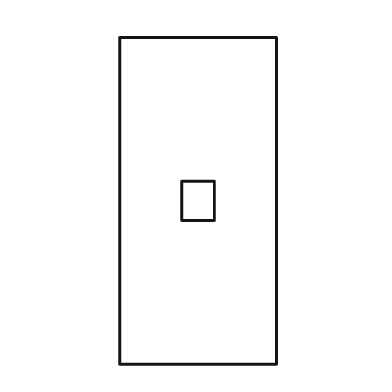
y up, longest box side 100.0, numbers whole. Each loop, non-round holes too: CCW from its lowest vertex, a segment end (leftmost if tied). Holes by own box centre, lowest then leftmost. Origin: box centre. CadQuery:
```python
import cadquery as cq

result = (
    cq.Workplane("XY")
    .moveTo(-24.0, -50.0)
    .lineTo(24.0, -50.0)
    .lineTo(24.0, 50.0)
    .lineTo(-24.0, 50.0)
    .close()
    .moveTo(-5.0, -6.0)
    .lineTo(5.0, -6.0)
    .lineTo(5.0, 6.0)
    .lineTo(-5.0, 6.0)
    .close()
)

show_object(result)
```